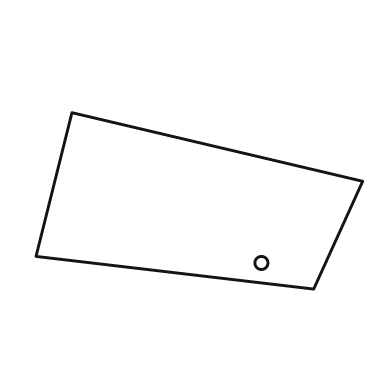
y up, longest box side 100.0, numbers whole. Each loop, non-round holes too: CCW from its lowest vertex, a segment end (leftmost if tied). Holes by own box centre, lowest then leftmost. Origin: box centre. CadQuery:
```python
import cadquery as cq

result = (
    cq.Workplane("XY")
    .moveTo(35.0, -27.0)
    .lineTo(50.0, 6.0)
    .lineTo(-39.0, 27.0)
    .lineTo(-50.0, -17.0)
    .close()
    .moveTo(19.0, -19.0)
    .circle(2.0)
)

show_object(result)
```